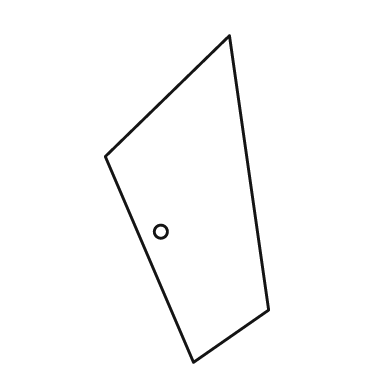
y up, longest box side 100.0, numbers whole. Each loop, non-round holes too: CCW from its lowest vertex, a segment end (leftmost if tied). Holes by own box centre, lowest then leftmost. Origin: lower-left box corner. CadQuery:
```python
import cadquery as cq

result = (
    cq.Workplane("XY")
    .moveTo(27.0, 0.0)
    .lineTo(50.0, 16.0)
    .lineTo(38.0, 100.0)
    .lineTo(0.0, 63.0)
    .close()
    .moveTo(17.0, 40.0)
    .circle(2.0)
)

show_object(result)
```